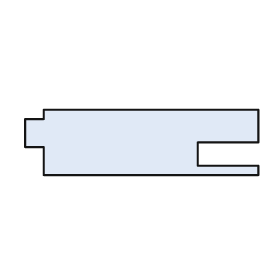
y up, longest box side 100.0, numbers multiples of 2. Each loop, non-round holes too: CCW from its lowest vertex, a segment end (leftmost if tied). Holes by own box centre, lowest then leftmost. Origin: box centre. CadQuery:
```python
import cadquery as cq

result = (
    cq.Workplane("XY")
    .moveTo(-42.0, -14.0)
    .lineTo(50.0, -14.0)
    .lineTo(50.0, -10.0)
    .lineTo(24.0, -10.0)
    .lineTo(24.0, 0.0)
    .lineTo(50.0, 0.0)
    .lineTo(50.0, 14.0)
    .lineTo(-42.0, 14.0)
    .lineTo(-42.0, 10.0)
    .lineTo(-50.0, 10.0)
    .lineTo(-50.0, -2.0)
    .lineTo(-42.0, -2.0)
    .close()
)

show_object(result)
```